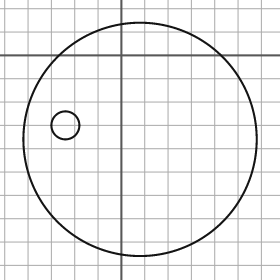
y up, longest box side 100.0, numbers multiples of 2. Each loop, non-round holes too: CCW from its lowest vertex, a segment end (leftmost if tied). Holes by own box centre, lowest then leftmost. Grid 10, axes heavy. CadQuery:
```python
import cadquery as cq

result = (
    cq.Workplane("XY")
    .moveTo(8.0, -36.0)
    .circle(50.0)
    .moveTo(-24.0, -30.0)
    .circle(6.0)
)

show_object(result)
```